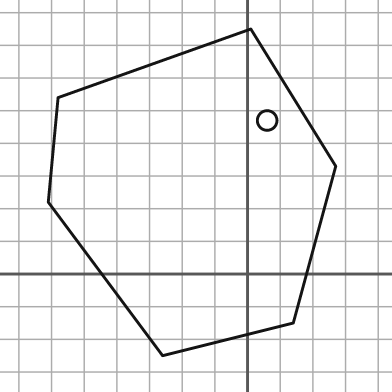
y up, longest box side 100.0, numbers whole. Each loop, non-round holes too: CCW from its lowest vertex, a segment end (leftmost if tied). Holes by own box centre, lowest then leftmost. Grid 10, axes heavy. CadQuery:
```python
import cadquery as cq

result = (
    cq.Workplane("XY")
    .moveTo(-26.0, -25.0)
    .lineTo(14.0, -15.0)
    .lineTo(27.0, 33.0)
    .lineTo(1.0, 75.0)
    .lineTo(-58.0, 54.0)
    .lineTo(-61.0, 22.0)
    .close()
    .moveTo(6.0, 47.0)
    .circle(3.0)
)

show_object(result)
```